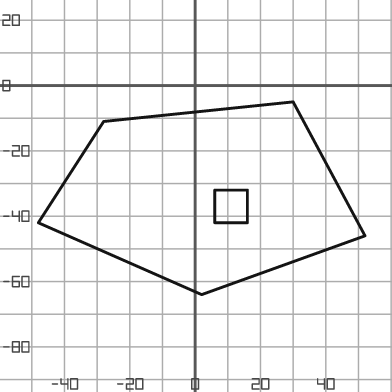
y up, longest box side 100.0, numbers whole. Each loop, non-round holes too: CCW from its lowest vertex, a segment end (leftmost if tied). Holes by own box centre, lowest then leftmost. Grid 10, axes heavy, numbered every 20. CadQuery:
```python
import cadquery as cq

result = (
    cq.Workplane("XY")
    .moveTo(2.0, -64.0)
    .lineTo(52.0, -46.0)
    .lineTo(30.0, -5.0)
    .lineTo(-28.0, -11.0)
    .lineTo(-48.0, -42.0)
    .close()
    .moveTo(6.0, -42.0)
    .lineTo(16.0, -42.0)
    .lineTo(16.0, -32.0)
    .lineTo(6.0, -32.0)
    .close()
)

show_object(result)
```